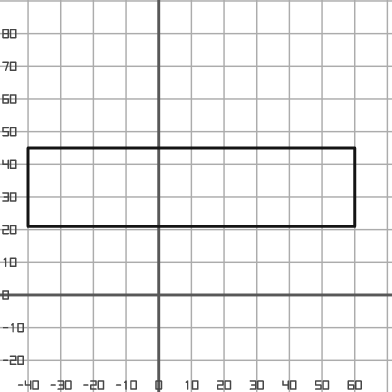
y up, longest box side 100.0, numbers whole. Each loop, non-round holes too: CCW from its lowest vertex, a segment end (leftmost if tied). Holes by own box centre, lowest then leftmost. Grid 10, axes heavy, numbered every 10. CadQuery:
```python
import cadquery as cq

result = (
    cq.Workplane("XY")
    .moveTo(-40.0, 21.0)
    .lineTo(60.0, 21.0)
    .lineTo(60.0, 45.0)
    .lineTo(-40.0, 45.0)
    .close()
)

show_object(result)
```